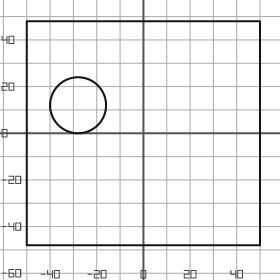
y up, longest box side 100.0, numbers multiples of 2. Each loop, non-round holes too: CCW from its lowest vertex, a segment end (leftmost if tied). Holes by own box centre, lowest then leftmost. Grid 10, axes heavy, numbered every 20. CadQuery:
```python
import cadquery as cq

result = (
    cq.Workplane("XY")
    .moveTo(-50.0, -48.0)
    .lineTo(50.0, -48.0)
    .lineTo(50.0, 48.0)
    .lineTo(-50.0, 48.0)
    .close()
    .moveTo(-28.0, 12.0)
    .circle(12.0)
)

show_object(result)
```